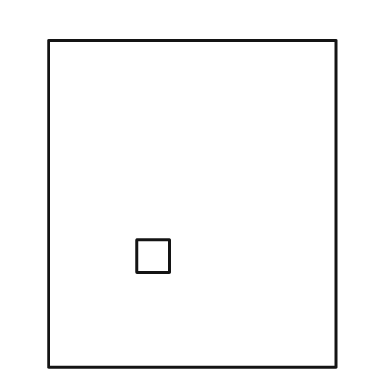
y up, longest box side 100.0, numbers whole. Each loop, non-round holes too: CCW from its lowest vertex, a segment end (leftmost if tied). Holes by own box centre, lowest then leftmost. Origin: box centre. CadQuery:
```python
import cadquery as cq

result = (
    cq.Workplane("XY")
    .moveTo(-44.0, -50.0)
    .lineTo(44.0, -50.0)
    .lineTo(44.0, 50.0)
    .lineTo(-44.0, 50.0)
    .close()
    .moveTo(-17.0, -21.0)
    .lineTo(-7.0, -21.0)
    .lineTo(-7.0, -11.0)
    .lineTo(-17.0, -11.0)
    .close()
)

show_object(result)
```